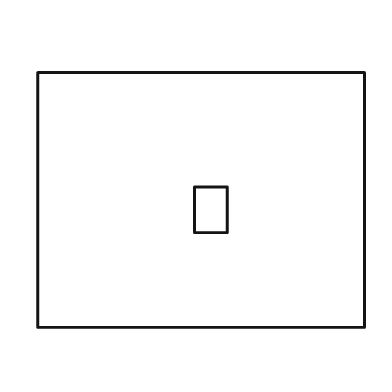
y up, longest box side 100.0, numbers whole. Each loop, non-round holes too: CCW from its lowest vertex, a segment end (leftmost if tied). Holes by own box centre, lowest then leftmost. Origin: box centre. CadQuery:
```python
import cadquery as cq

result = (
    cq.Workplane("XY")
    .moveTo(-50.0, -39.0)
    .lineTo(50.0, -39.0)
    .lineTo(50.0, 39.0)
    .lineTo(-50.0, 39.0)
    .close()
    .moveTo(-2.0, -10.0)
    .lineTo(8.0, -10.0)
    .lineTo(8.0, 4.0)
    .lineTo(-2.0, 4.0)
    .close()
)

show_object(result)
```